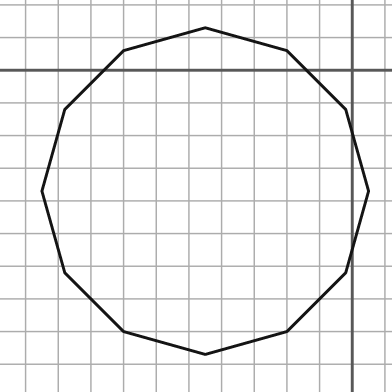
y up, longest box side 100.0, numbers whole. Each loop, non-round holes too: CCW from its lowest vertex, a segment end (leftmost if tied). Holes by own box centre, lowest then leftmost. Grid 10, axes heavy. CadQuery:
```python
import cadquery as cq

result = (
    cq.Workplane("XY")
    .moveTo(-45.0, -87.0)
    .lineTo(-20.0, -80.0)
    .lineTo(-2.0, -62.0)
    .lineTo(5.0, -37.0)
    .lineTo(-2.0, -12.0)
    .lineTo(-20.0, 6.0)
    .lineTo(-45.0, 13.0)
    .lineTo(-70.0, 6.0)
    .lineTo(-88.0, -12.0)
    .lineTo(-95.0, -37.0)
    .lineTo(-88.0, -62.0)
    .lineTo(-70.0, -80.0)
    .close()
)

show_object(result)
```